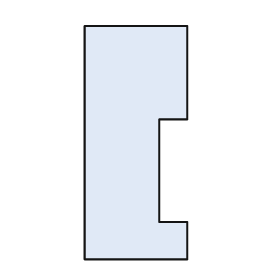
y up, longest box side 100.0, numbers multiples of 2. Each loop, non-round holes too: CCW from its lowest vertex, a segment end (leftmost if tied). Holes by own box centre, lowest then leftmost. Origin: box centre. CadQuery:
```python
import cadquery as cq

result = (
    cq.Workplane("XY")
    .moveTo(-22.0, -50.0)
    .lineTo(22.0, -50.0)
    .lineTo(22.0, -34.0)
    .lineTo(10.0, -34.0)
    .lineTo(10.0, 10.0)
    .lineTo(22.0, 10.0)
    .lineTo(22.0, 50.0)
    .lineTo(-22.0, 50.0)
    .close()
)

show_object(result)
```